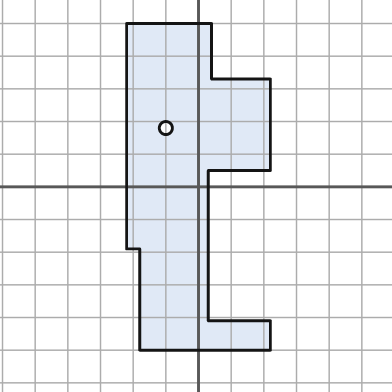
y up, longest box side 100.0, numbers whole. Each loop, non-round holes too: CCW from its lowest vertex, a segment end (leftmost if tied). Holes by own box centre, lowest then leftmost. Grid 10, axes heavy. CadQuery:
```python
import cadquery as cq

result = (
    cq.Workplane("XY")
    .moveTo(-18.0, -50.0)
    .lineTo(22.0, -50.0)
    .lineTo(22.0, -41.0)
    .lineTo(3.0, -41.0)
    .lineTo(3.0, 5.0)
    .lineTo(22.0, 5.0)
    .lineTo(22.0, 33.0)
    .lineTo(4.0, 33.0)
    .lineTo(4.0, 50.0)
    .lineTo(-22.0, 50.0)
    .lineTo(-22.0, -19.0)
    .lineTo(-18.0, -19.0)
    .close()
    .moveTo(-10.0, 18.0)
    .circle(2.0)
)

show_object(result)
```